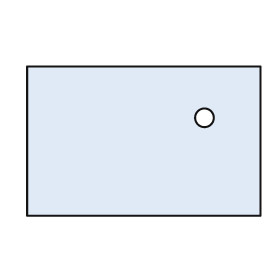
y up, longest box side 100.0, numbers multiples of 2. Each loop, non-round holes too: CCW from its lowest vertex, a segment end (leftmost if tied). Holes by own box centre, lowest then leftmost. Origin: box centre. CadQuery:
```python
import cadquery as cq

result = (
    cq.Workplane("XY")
    .moveTo(-50.0, -32.0)
    .lineTo(50.0, -32.0)
    .lineTo(50.0, 32.0)
    .lineTo(-50.0, 32.0)
    .close()
    .moveTo(26.0, 10.0)
    .circle(4.0)
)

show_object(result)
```